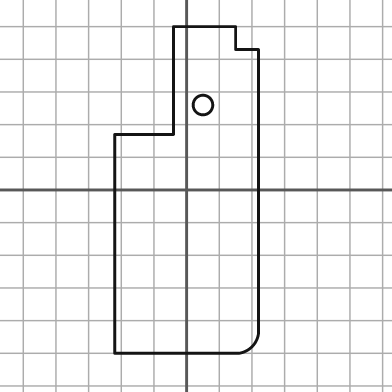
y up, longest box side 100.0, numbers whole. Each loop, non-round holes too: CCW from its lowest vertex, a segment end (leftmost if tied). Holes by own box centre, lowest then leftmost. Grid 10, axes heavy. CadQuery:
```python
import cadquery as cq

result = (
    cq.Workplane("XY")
    .moveTo(-22.0, -50.0)
    .lineTo(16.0, -50.0)
    .threePointArc((20.0, -48.0), (22.0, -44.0))
    .lineTo(22.0, 43.0)
    .lineTo(15.0, 43.0)
    .lineTo(15.0, 50.0)
    .lineTo(-4.0, 50.0)
    .lineTo(-4.0, 17.0)
    .lineTo(-22.0, 17.0)
    .close()
    .moveTo(5.0, 26.0)
    .circle(3.0)
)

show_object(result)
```